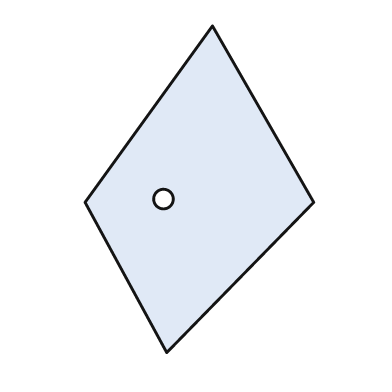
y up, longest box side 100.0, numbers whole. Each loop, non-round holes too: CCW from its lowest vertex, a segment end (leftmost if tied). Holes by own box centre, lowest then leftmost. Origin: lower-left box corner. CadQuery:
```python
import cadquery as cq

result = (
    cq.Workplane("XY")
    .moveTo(25.0, 0.0)
    .lineTo(70.0, 46.0)
    .lineTo(39.0, 100.0)
    .lineTo(0.0, 46.0)
    .close()
    .moveTo(24.0, 47.0)
    .circle(3.0)
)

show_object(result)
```